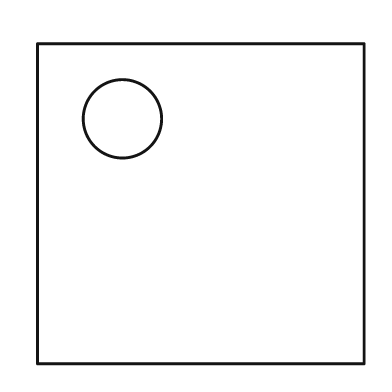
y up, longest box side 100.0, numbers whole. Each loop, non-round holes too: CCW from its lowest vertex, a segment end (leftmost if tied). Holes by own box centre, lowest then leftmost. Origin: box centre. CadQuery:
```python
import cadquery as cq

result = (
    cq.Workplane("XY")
    .moveTo(-50.0, -49.0)
    .lineTo(50.0, -49.0)
    .lineTo(50.0, 49.0)
    .lineTo(-50.0, 49.0)
    .close()
    .moveTo(-24.0, 26.0)
    .circle(12.0)
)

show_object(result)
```